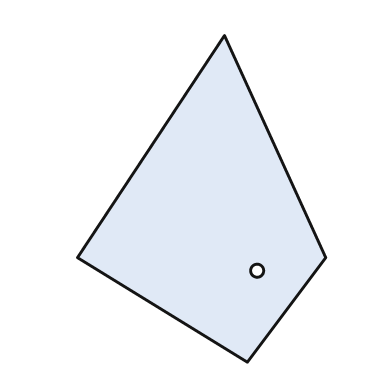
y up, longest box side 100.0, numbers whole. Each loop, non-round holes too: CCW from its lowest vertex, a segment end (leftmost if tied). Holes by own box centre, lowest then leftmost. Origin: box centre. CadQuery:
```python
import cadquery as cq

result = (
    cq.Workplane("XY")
    .moveTo(14.0, -50.0)
    .lineTo(38.0, -18.0)
    .lineTo(7.0, 50.0)
    .lineTo(-38.0, -18.0)
    .close()
    .moveTo(17.0, -22.0)
    .circle(2.0)
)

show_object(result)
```